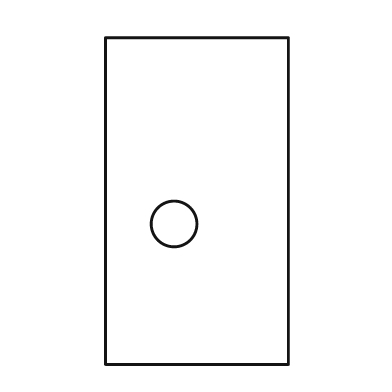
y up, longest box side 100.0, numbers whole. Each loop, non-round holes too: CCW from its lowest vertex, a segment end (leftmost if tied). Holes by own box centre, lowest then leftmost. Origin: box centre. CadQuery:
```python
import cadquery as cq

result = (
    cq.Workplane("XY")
    .moveTo(-28.0, -50.0)
    .lineTo(28.0, -50.0)
    .lineTo(28.0, 50.0)
    .lineTo(-28.0, 50.0)
    .close()
    .moveTo(-7.0, -7.0)
    .circle(7.0)
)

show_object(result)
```